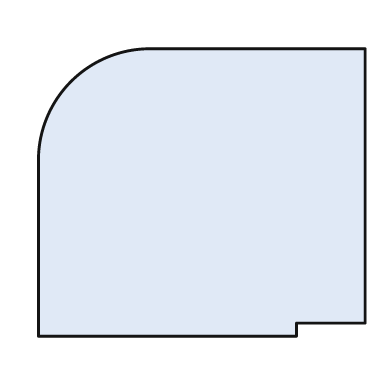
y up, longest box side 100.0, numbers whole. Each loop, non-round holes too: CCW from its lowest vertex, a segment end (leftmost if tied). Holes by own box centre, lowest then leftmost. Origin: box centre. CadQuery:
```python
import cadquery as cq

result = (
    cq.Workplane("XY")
    .moveTo(-50.0, -44.0)
    .lineTo(29.0, -44.0)
    .lineTo(29.0, -40.0)
    .lineTo(50.0, -40.0)
    .lineTo(50.0, 44.0)
    .lineTo(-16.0, 44.0)
    .threePointArc((-40.0, 34.0), (-50.0, 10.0))
    .close()
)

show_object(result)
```